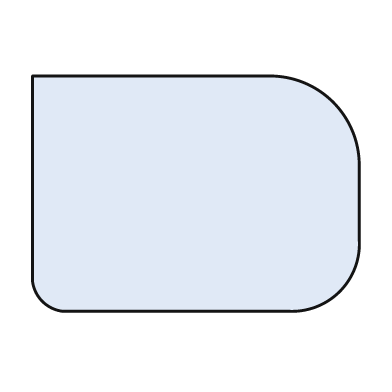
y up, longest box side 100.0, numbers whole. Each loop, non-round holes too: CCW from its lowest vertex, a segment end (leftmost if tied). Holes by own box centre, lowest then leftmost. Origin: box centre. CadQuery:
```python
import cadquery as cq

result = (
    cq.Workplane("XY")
    .moveTo(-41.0, -36.0)
    .lineTo(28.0, -36.0)
    .threePointArc((44.0, -30.0), (50.0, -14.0))
    .lineTo(50.0, 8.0)
    .threePointArc((42.0, 28.0), (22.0, 36.0))
    .lineTo(-50.0, 36.0)
    .lineTo(-50.0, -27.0)
    .threePointArc((-47.0, -33.0), (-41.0, -36.0))
    .close()
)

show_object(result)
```